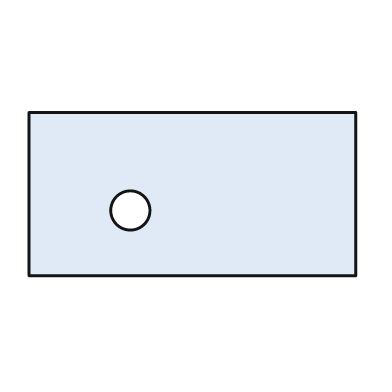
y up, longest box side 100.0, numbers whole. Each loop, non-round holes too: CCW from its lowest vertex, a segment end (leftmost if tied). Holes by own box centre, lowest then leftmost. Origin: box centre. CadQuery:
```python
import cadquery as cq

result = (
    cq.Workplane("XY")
    .moveTo(-50.0, -25.0)
    .lineTo(50.0, -25.0)
    .lineTo(50.0, 25.0)
    .lineTo(-50.0, 25.0)
    .close()
    .moveTo(-19.0, -5.0)
    .circle(6.0)
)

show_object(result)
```